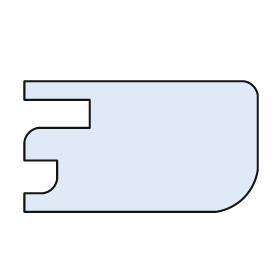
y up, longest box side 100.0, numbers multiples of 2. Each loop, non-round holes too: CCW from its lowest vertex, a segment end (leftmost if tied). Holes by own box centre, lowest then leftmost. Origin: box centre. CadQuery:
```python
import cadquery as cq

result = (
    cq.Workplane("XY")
    .moveTo(-50.0, -28.0)
    .lineTo(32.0, -28.0)
    .threePointArc((44.0, -22.0), (50.0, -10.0))
    .lineTo(50.0, 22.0)
    .threePointArc((48.0, 26.0), (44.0, 28.0))
    .lineTo(-50.0, 28.0)
    .lineTo(-50.0, 20.0)
    .lineTo(-22.0, 20.0)
    .lineTo(-22.0, 8.0)
    .lineTo(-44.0, 8.0)
    .threePointArc((-48.0, 6.0), (-50.0, 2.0))
    .lineTo(-50.0, -6.0)
    .lineTo(-36.0, -6.0)
    .lineTo(-36.0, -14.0)
    .threePointArc((-38.0, -18.0), (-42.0, -20.0))
    .lineTo(-50.0, -20.0)
    .close()
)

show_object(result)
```